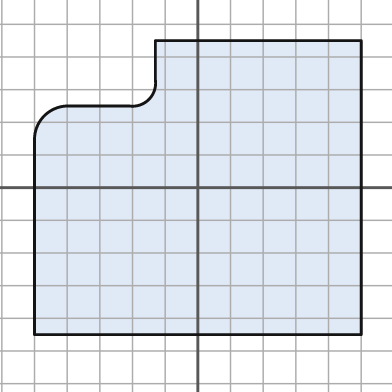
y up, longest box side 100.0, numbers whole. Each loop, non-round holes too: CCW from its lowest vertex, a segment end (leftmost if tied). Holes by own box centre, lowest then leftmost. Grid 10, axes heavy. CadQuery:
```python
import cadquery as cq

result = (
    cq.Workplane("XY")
    .moveTo(-50.0, -45.0)
    .lineTo(50.0, -45.0)
    .lineTo(50.0, 45.0)
    .lineTo(-13.0, 45.0)
    .lineTo(-13.0, 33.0)
    .threePointArc((-15.0, 27.0), (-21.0, 25.0))
    .lineTo(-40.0, 25.0)
    .threePointArc((-47.0, 22.0), (-50.0, 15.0))
    .close()
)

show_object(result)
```